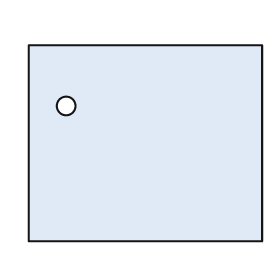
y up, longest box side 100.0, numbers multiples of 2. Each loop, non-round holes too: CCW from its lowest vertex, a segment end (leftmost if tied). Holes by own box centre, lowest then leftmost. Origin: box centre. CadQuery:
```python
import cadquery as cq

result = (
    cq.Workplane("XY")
    .moveTo(-50.0, -42.0)
    .lineTo(50.0, -42.0)
    .lineTo(50.0, 42.0)
    .lineTo(-50.0, 42.0)
    .close()
    .moveTo(-34.0, 16.0)
    .circle(4.0)
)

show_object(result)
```